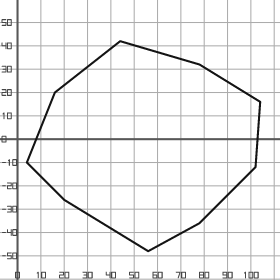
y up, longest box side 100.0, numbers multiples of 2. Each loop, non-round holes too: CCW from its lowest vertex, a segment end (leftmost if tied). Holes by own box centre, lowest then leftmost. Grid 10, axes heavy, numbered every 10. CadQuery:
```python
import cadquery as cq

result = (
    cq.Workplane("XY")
    .moveTo(56.0, -48.0)
    .lineTo(78.0, -36.0)
    .lineTo(102.0, -12.0)
    .lineTo(104.0, 16.0)
    .lineTo(78.0, 32.0)
    .lineTo(44.0, 42.0)
    .lineTo(16.0, 20.0)
    .lineTo(4.0, -10.0)
    .lineTo(20.0, -26.0)
    .close()
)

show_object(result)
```